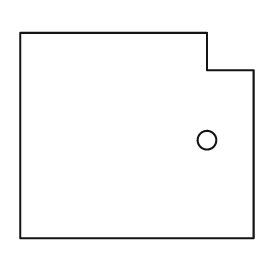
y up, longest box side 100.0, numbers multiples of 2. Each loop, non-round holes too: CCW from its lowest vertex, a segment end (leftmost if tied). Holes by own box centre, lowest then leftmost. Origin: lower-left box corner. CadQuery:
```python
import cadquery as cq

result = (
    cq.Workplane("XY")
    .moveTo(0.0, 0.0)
    .lineTo(100.0, 0.0)
    .lineTo(100.0, 72.0)
    .lineTo(80.0, 72.0)
    .lineTo(80.0, 88.0)
    .lineTo(0.0, 88.0)
    .close()
    .moveTo(80.0, 42.0)
    .circle(4.0)
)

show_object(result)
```